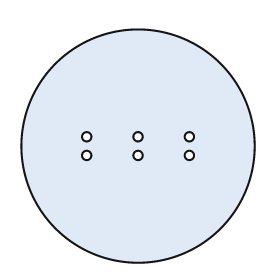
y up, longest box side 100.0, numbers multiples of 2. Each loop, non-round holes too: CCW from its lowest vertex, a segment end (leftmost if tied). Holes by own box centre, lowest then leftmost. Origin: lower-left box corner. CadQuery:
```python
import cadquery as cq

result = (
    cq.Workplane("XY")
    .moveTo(50.0, 50.0)
    .circle(50.0)
    .moveTo(28.0, 46.0)
    .circle(2.0)
    .moveTo(50.0, 46.0)
    .circle(2.0)
    .moveTo(72.0, 46.0)
    .circle(2.0)
    .moveTo(28.0, 54.0)
    .circle(2.0)
    .moveTo(50.0, 54.0)
    .circle(2.0)
    .moveTo(72.0, 54.0)
    .circle(2.0)
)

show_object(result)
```